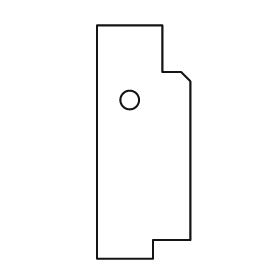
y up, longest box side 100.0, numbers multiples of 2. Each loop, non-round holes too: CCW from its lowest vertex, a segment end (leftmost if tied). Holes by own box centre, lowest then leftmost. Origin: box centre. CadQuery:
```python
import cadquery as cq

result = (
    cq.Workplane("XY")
    .moveTo(-20.0, -50.0)
    .lineTo(4.0, -50.0)
    .lineTo(4.0, -42.0)
    .lineTo(20.0, -42.0)
    .lineTo(20.0, 26.0)
    .lineTo(16.0, 30.0)
    .lineTo(8.0, 30.0)
    .lineTo(8.0, 50.0)
    .lineTo(-20.0, 50.0)
    .close()
    .moveTo(-6.0, 18.0)
    .circle(4.0)
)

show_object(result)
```